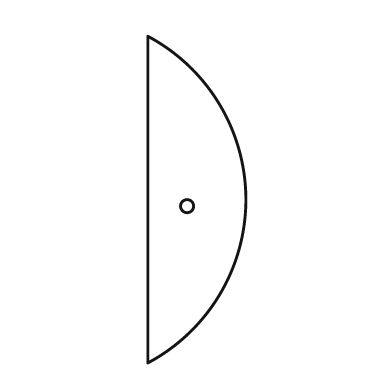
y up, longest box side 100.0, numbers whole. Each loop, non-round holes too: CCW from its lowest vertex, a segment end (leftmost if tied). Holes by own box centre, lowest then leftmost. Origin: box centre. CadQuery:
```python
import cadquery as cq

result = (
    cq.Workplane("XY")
    .moveTo(-15.0, -50.0)
    .threePointArc((15.0, 0.0), (-15.0, 50.0))
    .close()
    .moveTo(-3.0, -2.0)
    .circle(2.0)
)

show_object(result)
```